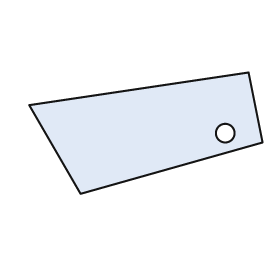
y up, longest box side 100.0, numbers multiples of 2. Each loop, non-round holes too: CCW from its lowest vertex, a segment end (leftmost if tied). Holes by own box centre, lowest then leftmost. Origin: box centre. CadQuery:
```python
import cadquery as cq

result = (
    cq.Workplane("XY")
    .moveTo(-28.0, -26.0)
    .lineTo(50.0, -4.0)
    .lineTo(44.0, 26.0)
    .lineTo(-50.0, 12.0)
    .close()
    .moveTo(34.0, 0.0)
    .circle(4.0)
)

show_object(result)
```